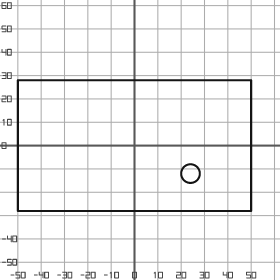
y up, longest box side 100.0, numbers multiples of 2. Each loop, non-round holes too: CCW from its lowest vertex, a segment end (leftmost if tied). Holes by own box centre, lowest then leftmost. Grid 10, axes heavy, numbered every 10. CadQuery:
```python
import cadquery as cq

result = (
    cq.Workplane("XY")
    .moveTo(-50.0, -28.0)
    .lineTo(50.0, -28.0)
    .lineTo(50.0, 28.0)
    .lineTo(-50.0, 28.0)
    .close()
    .moveTo(24.0, -12.0)
    .circle(4.0)
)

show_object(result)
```